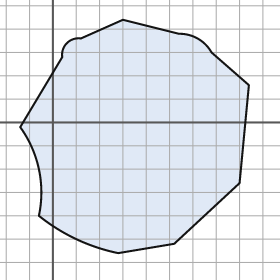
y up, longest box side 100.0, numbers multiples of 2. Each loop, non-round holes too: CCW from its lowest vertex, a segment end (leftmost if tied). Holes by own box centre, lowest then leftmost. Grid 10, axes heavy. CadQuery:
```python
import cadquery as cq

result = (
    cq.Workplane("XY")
    .moveTo(28.0, -56.0)
    .lineTo(52.0, -52.0)
    .lineTo(80.0, -26.0)
    .lineTo(84.0, 16.0)
    .lineTo(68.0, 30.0)
    .threePointArc((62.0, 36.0), (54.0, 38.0))
    .lineTo(30.0, 44.0)
    .lineTo(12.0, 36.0)
    .threePointArc((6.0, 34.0), (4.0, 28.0))
    .lineTo(-14.0, -2.0)
    .threePointArc((-6.0, -20.0), (-6.0, -40.0))
    .threePointArc((10.0, -50.0), (28.0, -56.0))
    .close()
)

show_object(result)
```